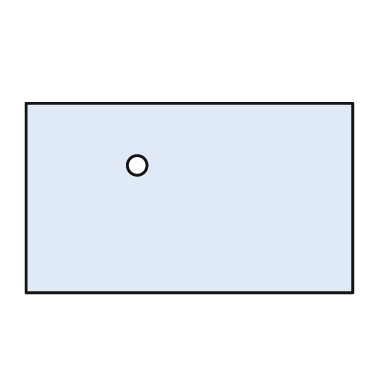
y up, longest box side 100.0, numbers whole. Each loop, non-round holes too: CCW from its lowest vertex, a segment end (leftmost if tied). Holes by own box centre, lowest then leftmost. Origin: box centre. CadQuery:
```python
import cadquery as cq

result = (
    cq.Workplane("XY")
    .moveTo(-50.0, -29.0)
    .lineTo(50.0, -29.0)
    .lineTo(50.0, 29.0)
    .lineTo(-50.0, 29.0)
    .close()
    .moveTo(-16.0, 10.0)
    .circle(3.0)
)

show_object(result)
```